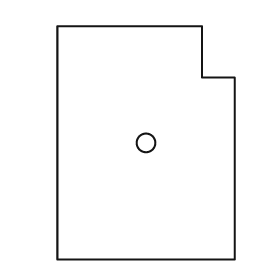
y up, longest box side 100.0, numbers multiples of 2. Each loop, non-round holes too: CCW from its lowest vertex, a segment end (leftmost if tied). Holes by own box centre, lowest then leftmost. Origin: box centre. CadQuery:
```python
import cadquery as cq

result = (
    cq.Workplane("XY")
    .moveTo(-38.0, -50.0)
    .lineTo(38.0, -50.0)
    .lineTo(38.0, 28.0)
    .lineTo(24.0, 28.0)
    .lineTo(24.0, 50.0)
    .lineTo(-38.0, 50.0)
    .close()
    .moveTo(0.0, 0.0)
    .circle(4.0)
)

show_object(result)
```